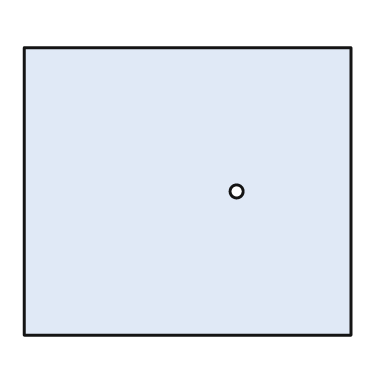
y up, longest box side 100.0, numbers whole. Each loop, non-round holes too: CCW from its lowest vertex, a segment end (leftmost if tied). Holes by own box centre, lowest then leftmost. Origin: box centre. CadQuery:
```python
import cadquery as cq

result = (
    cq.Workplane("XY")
    .moveTo(-50.0, -44.0)
    .lineTo(50.0, -44.0)
    .lineTo(50.0, 44.0)
    .lineTo(-50.0, 44.0)
    .close()
    .moveTo(15.0, 0.0)
    .circle(2.0)
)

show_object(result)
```